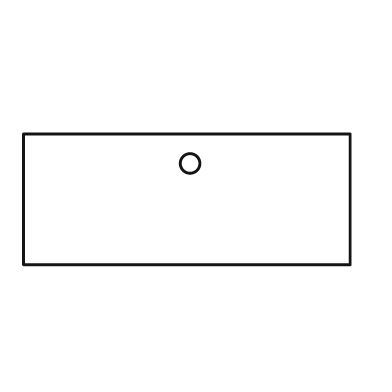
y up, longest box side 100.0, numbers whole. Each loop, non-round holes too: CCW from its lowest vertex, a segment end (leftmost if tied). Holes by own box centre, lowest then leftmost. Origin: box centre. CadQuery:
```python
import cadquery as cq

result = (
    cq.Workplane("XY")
    .moveTo(-50.0, -20.0)
    .lineTo(50.0, -20.0)
    .lineTo(50.0, 20.0)
    .lineTo(-50.0, 20.0)
    .close()
    .moveTo(1.0, 11.0)
    .circle(3.0)
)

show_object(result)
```